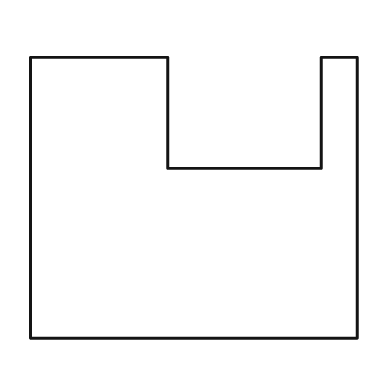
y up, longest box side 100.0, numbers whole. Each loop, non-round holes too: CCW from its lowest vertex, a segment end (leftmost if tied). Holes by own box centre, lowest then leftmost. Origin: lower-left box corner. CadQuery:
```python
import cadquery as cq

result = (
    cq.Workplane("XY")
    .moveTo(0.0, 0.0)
    .lineTo(100.0, 0.0)
    .lineTo(100.0, 86.0)
    .lineTo(89.0, 86.0)
    .lineTo(89.0, 52.0)
    .lineTo(42.0, 52.0)
    .lineTo(42.0, 86.0)
    .lineTo(0.0, 86.0)
    .close()
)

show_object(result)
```